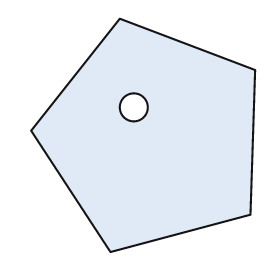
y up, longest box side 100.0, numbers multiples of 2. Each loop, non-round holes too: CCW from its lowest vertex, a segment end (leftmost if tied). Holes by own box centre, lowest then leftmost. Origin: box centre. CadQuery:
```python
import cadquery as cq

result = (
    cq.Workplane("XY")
    .moveTo(-14.0, -50.0)
    .lineTo(46.0, -34.0)
    .lineTo(48.0, 28.0)
    .lineTo(-10.0, 50.0)
    .lineTo(-48.0, 2.0)
    .close()
    .moveTo(-4.0, 12.0)
    .circle(6.0)
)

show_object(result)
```